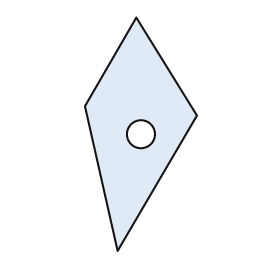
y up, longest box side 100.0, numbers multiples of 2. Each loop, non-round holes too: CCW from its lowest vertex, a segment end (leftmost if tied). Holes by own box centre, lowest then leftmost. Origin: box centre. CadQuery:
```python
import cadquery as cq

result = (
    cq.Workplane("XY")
    .moveTo(-10.0, -50.0)
    .lineTo(24.0, 8.0)
    .lineTo(-2.0, 50.0)
    .lineTo(-24.0, 12.0)
    .close()
    .moveTo(0.0, 0.0)
    .circle(6.0)
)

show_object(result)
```